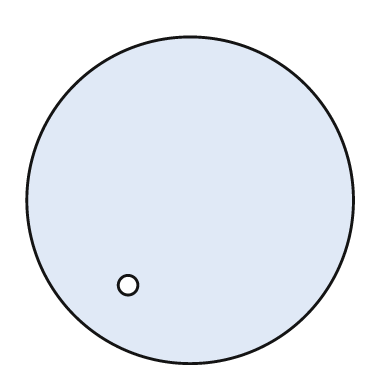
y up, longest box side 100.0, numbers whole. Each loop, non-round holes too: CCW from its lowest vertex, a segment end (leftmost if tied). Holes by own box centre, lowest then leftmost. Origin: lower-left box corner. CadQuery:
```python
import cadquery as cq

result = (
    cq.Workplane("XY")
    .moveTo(50.0, 50.0)
    .circle(50.0)
    .moveTo(31.0, 24.0)
    .circle(3.0)
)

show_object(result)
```